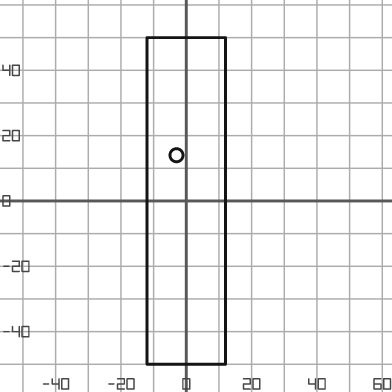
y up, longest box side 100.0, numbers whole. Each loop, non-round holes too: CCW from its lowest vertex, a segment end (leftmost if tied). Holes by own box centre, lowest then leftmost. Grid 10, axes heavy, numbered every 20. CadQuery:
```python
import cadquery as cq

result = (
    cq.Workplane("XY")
    .moveTo(-12.0, -50.0)
    .lineTo(12.0, -50.0)
    .lineTo(12.0, 50.0)
    .lineTo(-12.0, 50.0)
    .close()
    .moveTo(-3.0, 14.0)
    .circle(2.0)
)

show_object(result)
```